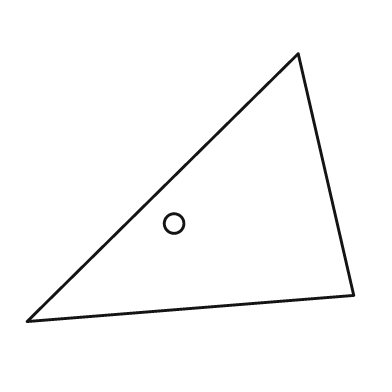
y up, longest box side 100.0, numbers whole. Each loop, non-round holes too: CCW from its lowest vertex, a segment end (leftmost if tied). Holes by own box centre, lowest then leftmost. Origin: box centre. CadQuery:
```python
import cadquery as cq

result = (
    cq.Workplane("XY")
    .moveTo(-50.0, -41.0)
    .lineTo(50.0, -33.0)
    .lineTo(33.0, 41.0)
    .close()
    .moveTo(-5.0, -11.0)
    .circle(3.0)
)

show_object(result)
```